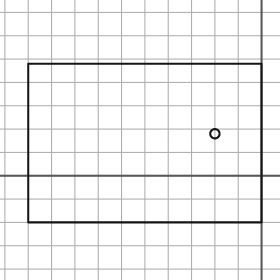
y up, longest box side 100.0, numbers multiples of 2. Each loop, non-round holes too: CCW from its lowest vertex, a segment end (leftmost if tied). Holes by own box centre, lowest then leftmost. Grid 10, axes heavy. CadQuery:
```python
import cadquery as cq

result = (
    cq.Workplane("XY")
    .moveTo(-100.0, -20.0)
    .lineTo(0.0, -20.0)
    .lineTo(0.0, 48.0)
    .lineTo(-100.0, 48.0)
    .close()
    .moveTo(-20.0, 18.0)
    .circle(2.0)
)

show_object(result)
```